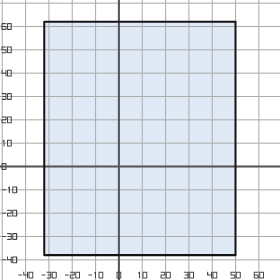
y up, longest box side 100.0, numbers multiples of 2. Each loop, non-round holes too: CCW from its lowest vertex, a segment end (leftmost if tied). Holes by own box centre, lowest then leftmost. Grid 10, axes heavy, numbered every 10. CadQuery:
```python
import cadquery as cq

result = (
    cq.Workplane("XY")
    .moveTo(-32.0, -38.0)
    .lineTo(50.0, -38.0)
    .lineTo(50.0, 62.0)
    .lineTo(-32.0, 62.0)
    .close()
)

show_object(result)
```